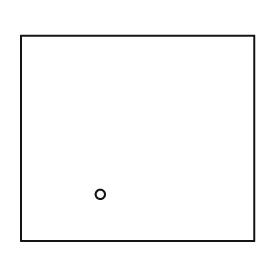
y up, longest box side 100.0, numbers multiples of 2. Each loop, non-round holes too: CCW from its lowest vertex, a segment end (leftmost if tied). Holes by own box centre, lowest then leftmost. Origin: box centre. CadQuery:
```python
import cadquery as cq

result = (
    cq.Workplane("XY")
    .moveTo(-50.0, -44.0)
    .lineTo(50.0, -44.0)
    .lineTo(50.0, 44.0)
    .lineTo(-50.0, 44.0)
    .close()
    .moveTo(-16.0, -24.0)
    .circle(2.0)
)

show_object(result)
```